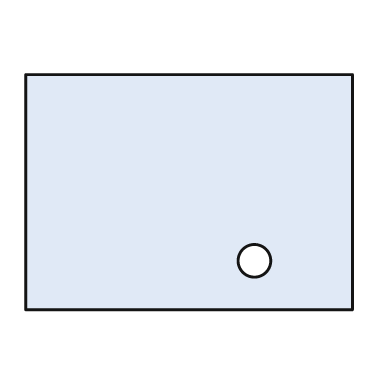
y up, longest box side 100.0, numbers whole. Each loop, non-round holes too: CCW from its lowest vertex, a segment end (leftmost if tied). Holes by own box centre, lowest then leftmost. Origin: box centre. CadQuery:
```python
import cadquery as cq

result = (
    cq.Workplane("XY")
    .moveTo(-50.0, -36.0)
    .lineTo(50.0, -36.0)
    .lineTo(50.0, 36.0)
    .lineTo(-50.0, 36.0)
    .close()
    .moveTo(20.0, -21.0)
    .circle(5.0)
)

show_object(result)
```